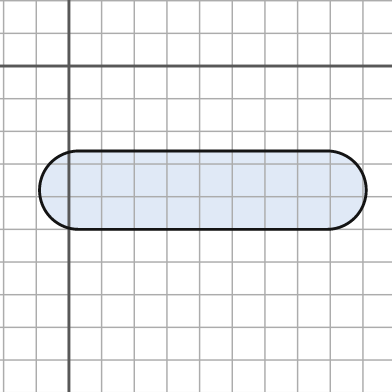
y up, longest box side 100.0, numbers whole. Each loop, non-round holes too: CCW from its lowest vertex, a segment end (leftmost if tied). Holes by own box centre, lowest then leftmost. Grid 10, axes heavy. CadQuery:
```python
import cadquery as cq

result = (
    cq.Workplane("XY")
    .moveTo(3.0, -50.0)
    .lineTo(79.0, -50.0)
    .threePointArc((91.0, -38.0), (79.0, -26.0))
    .lineTo(3.0, -26.0)
    .threePointArc((-9.0, -38.0), (3.0, -50.0))
    .close()
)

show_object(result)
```